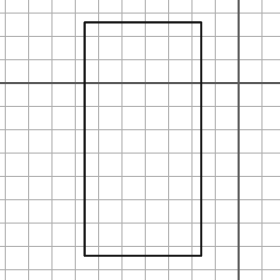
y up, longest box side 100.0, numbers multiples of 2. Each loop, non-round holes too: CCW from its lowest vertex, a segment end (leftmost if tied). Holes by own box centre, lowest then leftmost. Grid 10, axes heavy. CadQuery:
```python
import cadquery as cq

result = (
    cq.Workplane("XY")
    .moveTo(-66.0, -74.0)
    .lineTo(-16.0, -74.0)
    .lineTo(-16.0, 26.0)
    .lineTo(-66.0, 26.0)
    .close()
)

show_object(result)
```